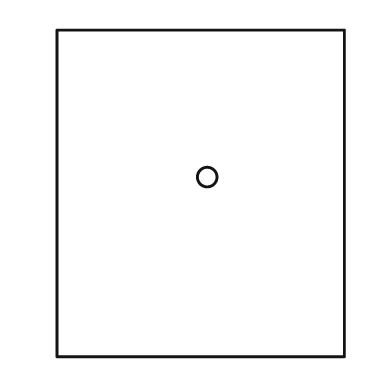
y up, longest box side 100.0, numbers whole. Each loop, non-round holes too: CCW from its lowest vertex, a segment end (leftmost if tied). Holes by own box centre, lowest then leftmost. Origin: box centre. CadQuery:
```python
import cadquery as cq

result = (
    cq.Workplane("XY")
    .moveTo(-44.0, -50.0)
    .lineTo(44.0, -50.0)
    .lineTo(44.0, 50.0)
    .lineTo(-44.0, 50.0)
    .close()
    .moveTo(2.0, 5.0)
    .circle(3.0)
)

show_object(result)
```